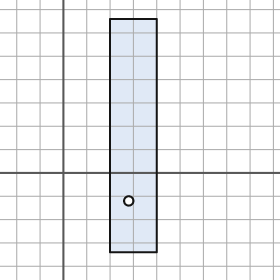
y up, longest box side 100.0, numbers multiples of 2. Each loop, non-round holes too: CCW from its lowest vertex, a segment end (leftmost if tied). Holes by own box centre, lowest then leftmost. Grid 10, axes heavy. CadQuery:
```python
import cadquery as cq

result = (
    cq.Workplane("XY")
    .moveTo(20.0, -34.0)
    .lineTo(40.0, -34.0)
    .lineTo(40.0, 66.0)
    .lineTo(20.0, 66.0)
    .close()
    .moveTo(28.0, -12.0)
    .circle(2.0)
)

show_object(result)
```